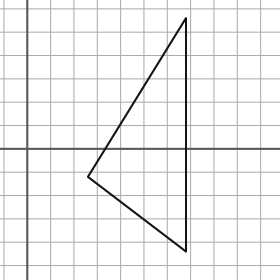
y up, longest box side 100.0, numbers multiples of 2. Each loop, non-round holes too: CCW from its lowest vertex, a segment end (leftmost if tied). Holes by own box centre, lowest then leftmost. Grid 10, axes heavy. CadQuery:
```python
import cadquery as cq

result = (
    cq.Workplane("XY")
    .moveTo(68.0, -44.0)
    .lineTo(68.0, 56.0)
    .lineTo(26.0, -12.0)
    .close()
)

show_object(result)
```